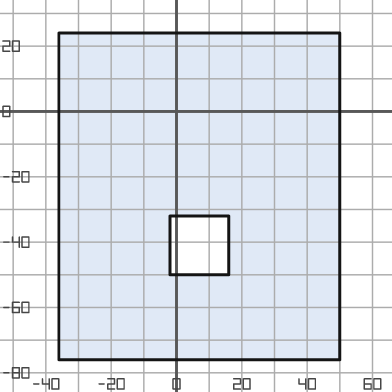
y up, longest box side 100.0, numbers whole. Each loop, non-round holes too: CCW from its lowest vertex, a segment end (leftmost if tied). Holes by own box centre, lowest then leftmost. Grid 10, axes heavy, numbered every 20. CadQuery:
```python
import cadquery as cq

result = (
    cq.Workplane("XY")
    .moveTo(-36.0, -76.0)
    .lineTo(50.0, -76.0)
    .lineTo(50.0, 24.0)
    .lineTo(-36.0, 24.0)
    .close()
    .moveTo(-2.0, -50.0)
    .lineTo(16.0, -50.0)
    .lineTo(16.0, -32.0)
    .lineTo(-2.0, -32.0)
    .close()
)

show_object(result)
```